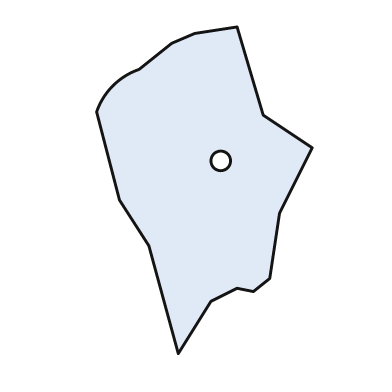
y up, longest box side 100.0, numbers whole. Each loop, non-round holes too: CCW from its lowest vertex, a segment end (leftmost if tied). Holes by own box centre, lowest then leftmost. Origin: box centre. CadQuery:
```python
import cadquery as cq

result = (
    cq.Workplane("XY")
    .moveTo(-8.0, -50.0)
    .lineTo(2.0, -34.0)
    .lineTo(10.0, -30.0)
    .lineTo(15.0, -31.0)
    .lineTo(20.0, -27.0)
    .lineTo(23.0, -7.0)
    .lineTo(33.0, 13.0)
    .lineTo(18.0, 23.0)
    .lineTo(10.0, 50.0)
    .lineTo(-3.0, 48.0)
    .lineTo(-10.0, 45.0)
    .lineTo(-20.0, 37.0)
    .threePointArc((-28.0, 32.0), (-33.0, 24.0))
    .lineTo(-26.0, -3.0)
    .lineTo(-17.0, -17.0)
    .close()
    .moveTo(5.0, 9.0)
    .circle(3.0)
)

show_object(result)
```